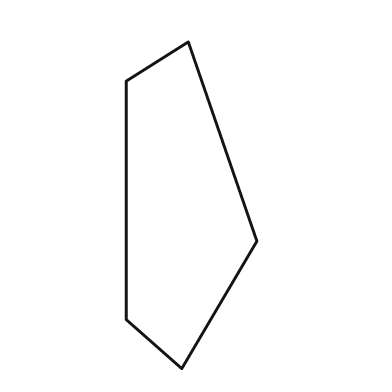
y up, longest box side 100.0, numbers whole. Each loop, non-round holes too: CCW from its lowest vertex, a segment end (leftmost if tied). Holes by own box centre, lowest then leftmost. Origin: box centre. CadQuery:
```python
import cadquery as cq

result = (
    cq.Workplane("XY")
    .moveTo(-3.0, -50.0)
    .lineTo(20.0, -11.0)
    .lineTo(-1.0, 50.0)
    .lineTo(-20.0, 38.0)
    .lineTo(-20.0, -35.0)
    .close()
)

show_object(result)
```